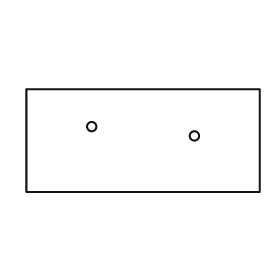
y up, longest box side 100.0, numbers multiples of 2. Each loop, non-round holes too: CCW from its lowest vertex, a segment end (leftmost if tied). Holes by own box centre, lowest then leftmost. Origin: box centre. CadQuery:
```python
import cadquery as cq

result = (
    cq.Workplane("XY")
    .moveTo(-50.0, -22.0)
    .lineTo(50.0, -22.0)
    .lineTo(50.0, 22.0)
    .lineTo(-50.0, 22.0)
    .close()
    .moveTo(22.0, 2.0)
    .circle(2.0)
    .moveTo(-22.0, 6.0)
    .circle(2.0)
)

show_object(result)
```